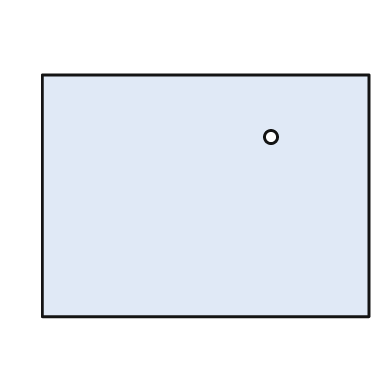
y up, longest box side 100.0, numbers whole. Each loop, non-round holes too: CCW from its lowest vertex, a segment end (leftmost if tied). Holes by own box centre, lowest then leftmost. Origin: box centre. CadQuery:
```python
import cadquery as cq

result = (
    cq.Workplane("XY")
    .moveTo(-50.0, -37.0)
    .lineTo(50.0, -37.0)
    .lineTo(50.0, 37.0)
    .lineTo(-50.0, 37.0)
    .close()
    .moveTo(20.0, 18.0)
    .circle(2.0)
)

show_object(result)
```